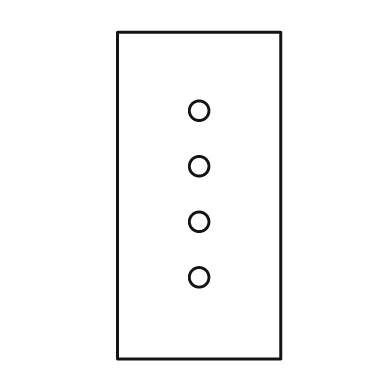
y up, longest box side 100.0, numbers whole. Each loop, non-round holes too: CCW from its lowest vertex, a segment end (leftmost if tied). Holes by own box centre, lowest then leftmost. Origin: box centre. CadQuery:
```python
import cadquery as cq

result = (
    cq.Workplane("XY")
    .moveTo(-25.0, -50.0)
    .lineTo(25.0, -50.0)
    .lineTo(25.0, 50.0)
    .lineTo(-25.0, 50.0)
    .close()
    .moveTo(0.0, -25.0)
    .circle(3.0)
    .moveTo(0.0, -8.0)
    .circle(3.0)
    .moveTo(0.0, 9.0)
    .circle(3.0)
    .moveTo(0.0, 26.0)
    .circle(3.0)
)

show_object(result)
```